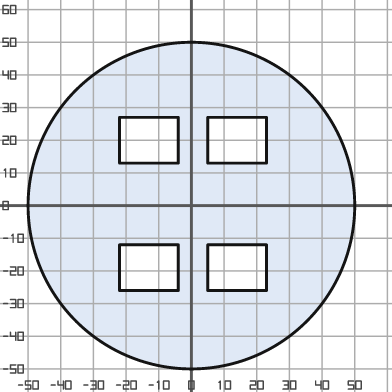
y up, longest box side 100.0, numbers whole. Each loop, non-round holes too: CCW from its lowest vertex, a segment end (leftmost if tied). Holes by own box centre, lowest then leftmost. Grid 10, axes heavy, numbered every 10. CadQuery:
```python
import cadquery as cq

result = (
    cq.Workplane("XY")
    .moveTo(0.0, 0.0)
    .circle(50.0)
    .moveTo(-22.0, -26.0)
    .lineTo(-4.0, -26.0)
    .lineTo(-4.0, -12.0)
    .lineTo(-22.0, -12.0)
    .close()
    .moveTo(5.0, -26.0)
    .lineTo(23.0, -26.0)
    .lineTo(23.0, -12.0)
    .lineTo(5.0, -12.0)
    .close()
    .moveTo(-22.0, 13.0)
    .lineTo(-4.0, 13.0)
    .lineTo(-4.0, 27.0)
    .lineTo(-22.0, 27.0)
    .close()
    .moveTo(5.0, 13.0)
    .lineTo(23.0, 13.0)
    .lineTo(23.0, 27.0)
    .lineTo(5.0, 27.0)
    .close()
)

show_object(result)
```